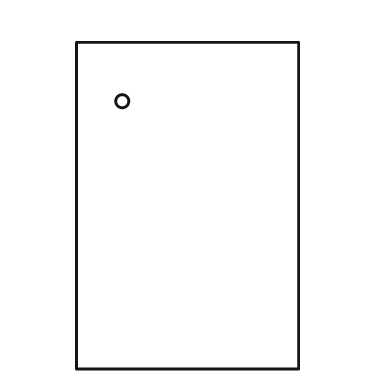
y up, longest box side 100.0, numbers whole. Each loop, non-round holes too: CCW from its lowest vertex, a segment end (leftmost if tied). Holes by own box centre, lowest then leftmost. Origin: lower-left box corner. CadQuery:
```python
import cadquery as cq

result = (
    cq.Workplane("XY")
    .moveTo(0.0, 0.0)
    .lineTo(68.0, 0.0)
    .lineTo(68.0, 100.0)
    .lineTo(0.0, 100.0)
    .close()
    .moveTo(14.0, 82.0)
    .circle(2.0)
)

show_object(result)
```